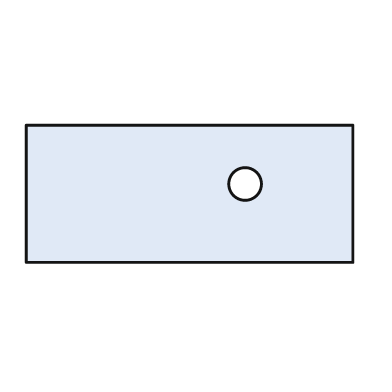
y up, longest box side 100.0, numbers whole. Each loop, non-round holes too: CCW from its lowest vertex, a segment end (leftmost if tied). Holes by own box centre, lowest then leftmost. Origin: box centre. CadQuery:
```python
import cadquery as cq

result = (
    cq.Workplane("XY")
    .moveTo(-50.0, -21.0)
    .lineTo(50.0, -21.0)
    .lineTo(50.0, 21.0)
    .lineTo(-50.0, 21.0)
    .close()
    .moveTo(17.0, 3.0)
    .circle(5.0)
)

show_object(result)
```